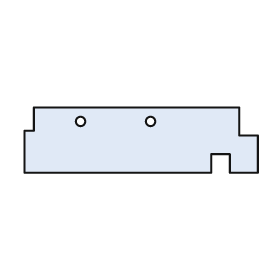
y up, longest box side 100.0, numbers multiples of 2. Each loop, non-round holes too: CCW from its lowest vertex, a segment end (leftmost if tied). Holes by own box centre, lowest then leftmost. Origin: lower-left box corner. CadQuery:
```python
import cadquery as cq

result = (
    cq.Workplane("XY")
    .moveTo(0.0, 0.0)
    .lineTo(80.0, 0.0)
    .lineTo(80.0, 8.0)
    .lineTo(88.0, 8.0)
    .lineTo(88.0, 0.0)
    .lineTo(100.0, 0.0)
    .lineTo(100.0, 16.0)
    .lineTo(92.0, 16.0)
    .lineTo(92.0, 28.0)
    .lineTo(4.0, 28.0)
    .lineTo(4.0, 18.0)
    .lineTo(0.0, 18.0)
    .close()
    .moveTo(24.0, 22.0)
    .circle(2.0)
    .moveTo(54.0, 22.0)
    .circle(2.0)
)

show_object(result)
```